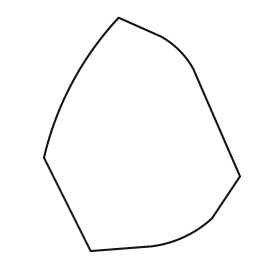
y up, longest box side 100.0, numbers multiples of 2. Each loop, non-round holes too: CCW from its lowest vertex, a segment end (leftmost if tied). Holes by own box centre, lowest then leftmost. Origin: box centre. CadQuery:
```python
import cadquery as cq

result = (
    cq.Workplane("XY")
    .moveTo(-22.0, -50.0)
    .lineTo(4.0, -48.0)
    .threePointArc((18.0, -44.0), (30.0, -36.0))
    .lineTo(42.0, -18.0)
    .lineTo(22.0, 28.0)
    .threePointArc((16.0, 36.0), (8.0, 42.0))
    .lineTo(-10.0, 50.0)
    .threePointArc((-30.0, 22.0), (-42.0, -10.0))
    .close()
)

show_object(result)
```